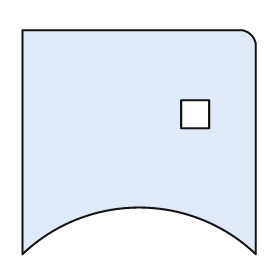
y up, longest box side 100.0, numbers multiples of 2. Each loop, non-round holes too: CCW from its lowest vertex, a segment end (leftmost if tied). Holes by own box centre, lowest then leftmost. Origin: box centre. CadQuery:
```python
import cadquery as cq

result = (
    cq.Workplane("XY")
    .moveTo(-50.0, -48.0)
    .threePointArc((0.0, -28.0), (50.0, -48.0))
    .lineTo(50.0, 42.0)
    .threePointArc((48.0, 46.0), (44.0, 48.0))
    .lineTo(-50.0, 48.0)
    .close()
    .moveTo(18.0, 6.0)
    .lineTo(30.0, 6.0)
    .lineTo(30.0, 18.0)
    .lineTo(18.0, 18.0)
    .close()
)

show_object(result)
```